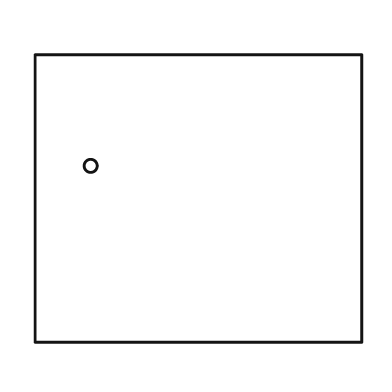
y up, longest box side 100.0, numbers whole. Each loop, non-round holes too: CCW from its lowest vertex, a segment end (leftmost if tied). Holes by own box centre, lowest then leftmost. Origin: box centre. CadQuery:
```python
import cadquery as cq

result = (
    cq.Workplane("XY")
    .moveTo(-50.0, -44.0)
    .lineTo(50.0, -44.0)
    .lineTo(50.0, 44.0)
    .lineTo(-50.0, 44.0)
    .close()
    .moveTo(-33.0, 10.0)
    .circle(2.0)
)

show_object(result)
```